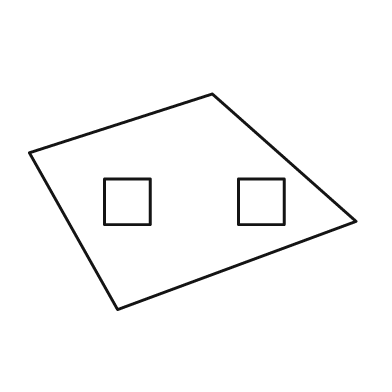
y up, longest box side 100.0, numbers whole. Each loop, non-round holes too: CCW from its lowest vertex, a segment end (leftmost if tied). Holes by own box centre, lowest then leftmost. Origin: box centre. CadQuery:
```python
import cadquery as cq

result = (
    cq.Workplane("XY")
    .moveTo(-23.0, -33.0)
    .lineTo(50.0, -6.0)
    .lineTo(6.0, 33.0)
    .lineTo(-50.0, 15.0)
    .close()
    .moveTo(-27.0, -7.0)
    .lineTo(-13.0, -7.0)
    .lineTo(-13.0, 7.0)
    .lineTo(-27.0, 7.0)
    .close()
    .moveTo(14.0, -7.0)
    .lineTo(28.0, -7.0)
    .lineTo(28.0, 7.0)
    .lineTo(14.0, 7.0)
    .close()
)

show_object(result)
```